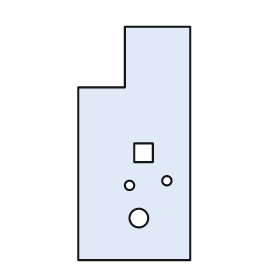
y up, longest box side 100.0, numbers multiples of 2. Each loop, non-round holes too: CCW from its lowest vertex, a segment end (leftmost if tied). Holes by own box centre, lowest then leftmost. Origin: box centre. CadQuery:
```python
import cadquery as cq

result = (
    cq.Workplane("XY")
    .moveTo(-24.0, -50.0)
    .lineTo(24.0, -50.0)
    .lineTo(24.0, 50.0)
    .lineTo(-4.0, 50.0)
    .lineTo(-4.0, 24.0)
    .lineTo(-24.0, 24.0)
    .close()
    .moveTo(2.0, -32.0)
    .circle(4.0)
    .moveTo(-2.0, -18.0)
    .circle(2.0)
    .moveTo(14.0, -16.0)
    .circle(2.0)
    .moveTo(0.0, -8.0)
    .lineTo(8.0, -8.0)
    .lineTo(8.0, 0.0)
    .lineTo(0.0, 0.0)
    .close()
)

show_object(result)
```